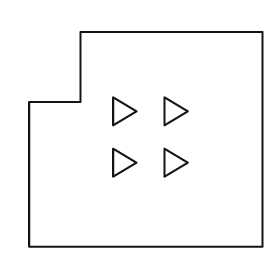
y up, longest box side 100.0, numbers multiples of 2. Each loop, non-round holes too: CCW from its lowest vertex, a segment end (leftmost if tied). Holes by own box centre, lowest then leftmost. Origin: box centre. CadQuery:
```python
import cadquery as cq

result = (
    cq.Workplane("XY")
    .moveTo(-50.0, -46.0)
    .lineTo(50.0, -46.0)
    .lineTo(50.0, 46.0)
    .lineTo(-28.0, 46.0)
    .lineTo(-28.0, 16.0)
    .lineTo(-50.0, 16.0)
    .close()
    .moveTo(-14.0, -16.0)
    .lineTo(-4.0, -10.0)
    .lineTo(-14.0, -4.0)
    .close()
    .moveTo(8.0, -16.0)
    .lineTo(18.0, -10.0)
    .lineTo(8.0, -4.0)
    .close()
    .moveTo(-14.0, 6.0)
    .lineTo(-4.0, 12.0)
    .lineTo(-14.0, 18.0)
    .close()
    .moveTo(8.0, 6.0)
    .lineTo(18.0, 12.0)
    .lineTo(8.0, 18.0)
    .close()
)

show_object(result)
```